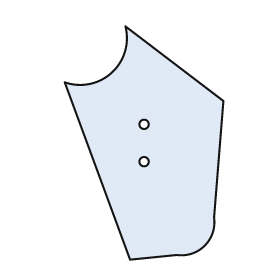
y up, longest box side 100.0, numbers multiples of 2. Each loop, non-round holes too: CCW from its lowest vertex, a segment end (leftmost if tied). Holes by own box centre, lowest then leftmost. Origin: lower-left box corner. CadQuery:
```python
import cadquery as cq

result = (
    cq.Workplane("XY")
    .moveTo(28.0, 0.0)
    .lineTo(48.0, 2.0)
    .threePointArc((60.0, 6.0), (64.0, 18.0))
    .lineTo(68.0, 68.0)
    .lineTo(26.0, 100.0)
    .threePointArc((20.0, 80.0), (0.0, 76.0))
    .close()
    .moveTo(34.0, 42.0)
    .circle(2.0)
    .moveTo(34.0, 58.0)
    .circle(2.0)
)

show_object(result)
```